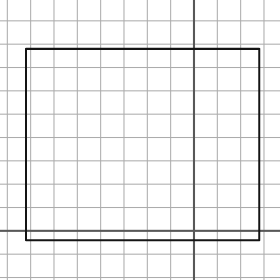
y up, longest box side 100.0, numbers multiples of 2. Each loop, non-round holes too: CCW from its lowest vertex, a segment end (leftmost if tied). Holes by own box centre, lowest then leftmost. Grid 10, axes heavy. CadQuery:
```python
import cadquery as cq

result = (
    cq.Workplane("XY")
    .moveTo(-72.0, -4.0)
    .lineTo(28.0, -4.0)
    .lineTo(28.0, 78.0)
    .lineTo(-72.0, 78.0)
    .close()
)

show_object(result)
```